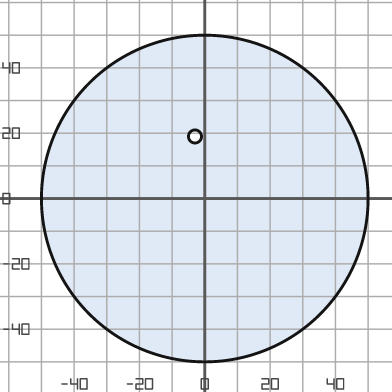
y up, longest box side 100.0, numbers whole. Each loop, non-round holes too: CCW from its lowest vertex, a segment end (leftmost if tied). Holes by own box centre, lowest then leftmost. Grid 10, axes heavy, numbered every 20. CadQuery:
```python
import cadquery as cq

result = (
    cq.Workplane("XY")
    .moveTo(0.0, 0.0)
    .circle(50.0)
    .moveTo(-3.0, 19.0)
    .circle(2.0)
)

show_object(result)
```